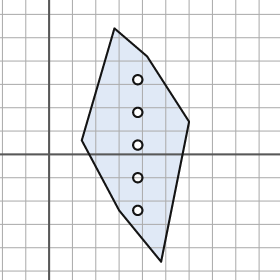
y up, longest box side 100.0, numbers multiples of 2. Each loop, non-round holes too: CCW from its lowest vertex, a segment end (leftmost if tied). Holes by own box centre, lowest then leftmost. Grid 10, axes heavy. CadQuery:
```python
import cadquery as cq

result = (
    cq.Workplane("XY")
    .moveTo(48.0, -46.0)
    .lineTo(60.0, 14.0)
    .lineTo(42.0, 42.0)
    .lineTo(28.0, 54.0)
    .lineTo(14.0, 6.0)
    .lineTo(30.0, -24.0)
    .close()
    .moveTo(38.0, -24.0)
    .circle(2.0)
    .moveTo(38.0, -10.0)
    .circle(2.0)
    .moveTo(38.0, 4.0)
    .circle(2.0)
    .moveTo(38.0, 18.0)
    .circle(2.0)
    .moveTo(38.0, 32.0)
    .circle(2.0)
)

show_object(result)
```